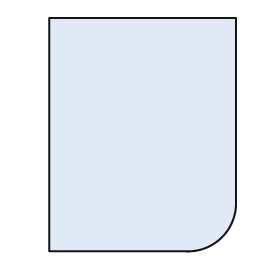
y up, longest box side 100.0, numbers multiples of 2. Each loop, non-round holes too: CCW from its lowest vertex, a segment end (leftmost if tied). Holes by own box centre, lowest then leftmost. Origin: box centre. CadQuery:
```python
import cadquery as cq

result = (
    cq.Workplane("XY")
    .moveTo(-40.0, -50.0)
    .lineTo(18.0, -50.0)
    .threePointArc((34.0, -44.0), (40.0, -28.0))
    .lineTo(40.0, 50.0)
    .lineTo(-40.0, 50.0)
    .close()
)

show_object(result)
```